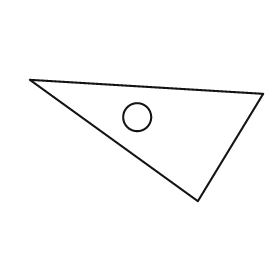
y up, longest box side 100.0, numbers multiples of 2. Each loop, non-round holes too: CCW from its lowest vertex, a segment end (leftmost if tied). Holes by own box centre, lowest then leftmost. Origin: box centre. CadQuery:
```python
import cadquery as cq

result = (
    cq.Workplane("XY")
    .moveTo(22.0, -26.0)
    .lineTo(50.0, 20.0)
    .lineTo(-50.0, 26.0)
    .close()
    .moveTo(-4.0, 10.0)
    .circle(6.0)
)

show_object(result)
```